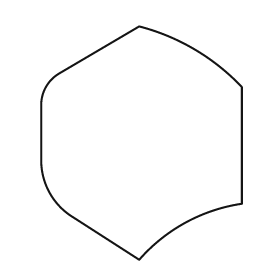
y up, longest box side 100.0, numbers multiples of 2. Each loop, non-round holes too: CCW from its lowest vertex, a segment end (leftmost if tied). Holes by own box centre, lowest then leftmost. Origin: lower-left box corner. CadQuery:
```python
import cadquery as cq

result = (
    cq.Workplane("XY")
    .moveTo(42.0, 0.0)
    .threePointArc((62.0, 16.0), (86.0, 24.0))
    .lineTo(86.0, 74.0)
    .threePointArc((66.0, 90.0), (42.0, 100.0))
    .lineTo(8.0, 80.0)
    .threePointArc((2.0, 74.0), (0.0, 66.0))
    .lineTo(0.0, 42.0)
    .threePointArc((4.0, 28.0), (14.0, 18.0))
    .close()
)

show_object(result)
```